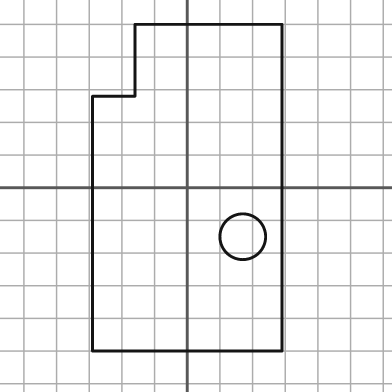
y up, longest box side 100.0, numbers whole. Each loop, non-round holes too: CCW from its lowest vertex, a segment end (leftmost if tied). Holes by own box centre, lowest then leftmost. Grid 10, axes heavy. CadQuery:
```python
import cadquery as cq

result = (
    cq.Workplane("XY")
    .moveTo(-29.0, -50.0)
    .lineTo(29.0, -50.0)
    .lineTo(29.0, 50.0)
    .lineTo(-16.0, 50.0)
    .lineTo(-16.0, 28.0)
    .lineTo(-29.0, 28.0)
    .close()
    .moveTo(17.0, -15.0)
    .circle(7.0)
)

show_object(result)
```